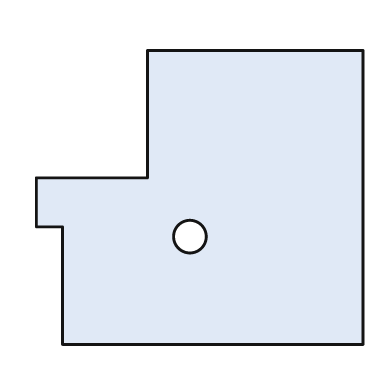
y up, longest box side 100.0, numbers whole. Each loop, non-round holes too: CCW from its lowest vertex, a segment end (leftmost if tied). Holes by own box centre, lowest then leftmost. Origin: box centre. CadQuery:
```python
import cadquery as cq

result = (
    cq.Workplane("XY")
    .moveTo(-42.0, -45.0)
    .lineTo(50.0, -45.0)
    .lineTo(50.0, 45.0)
    .lineTo(-16.0, 45.0)
    .lineTo(-16.0, 6.0)
    .lineTo(-50.0, 6.0)
    .lineTo(-50.0, -9.0)
    .lineTo(-42.0, -9.0)
    .close()
    .moveTo(-3.0, -12.0)
    .circle(5.0)
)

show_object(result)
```